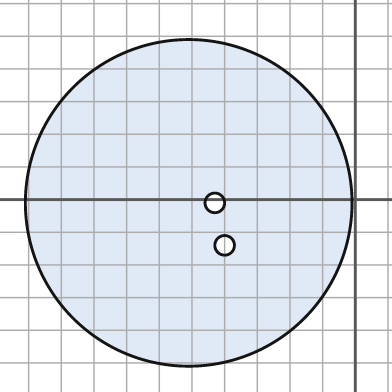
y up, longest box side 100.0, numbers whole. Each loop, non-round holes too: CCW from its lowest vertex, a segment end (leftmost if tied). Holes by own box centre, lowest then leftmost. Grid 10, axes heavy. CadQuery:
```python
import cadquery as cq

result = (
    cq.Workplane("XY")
    .moveTo(-51.0, -1.0)
    .circle(50.0)
    .moveTo(-40.0, -14.0)
    .circle(3.0)
    .moveTo(-43.0, -1.0)
    .circle(3.0)
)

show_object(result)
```